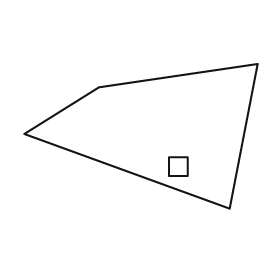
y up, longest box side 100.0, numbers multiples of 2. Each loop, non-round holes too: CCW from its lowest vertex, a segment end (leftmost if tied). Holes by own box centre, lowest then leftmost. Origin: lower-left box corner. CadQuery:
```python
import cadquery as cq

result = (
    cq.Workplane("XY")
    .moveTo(88.0, 0.0)
    .lineTo(100.0, 62.0)
    .lineTo(32.0, 52.0)
    .lineTo(0.0, 32.0)
    .close()
    .moveTo(62.0, 14.0)
    .lineTo(70.0, 14.0)
    .lineTo(70.0, 22.0)
    .lineTo(62.0, 22.0)
    .close()
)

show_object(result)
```